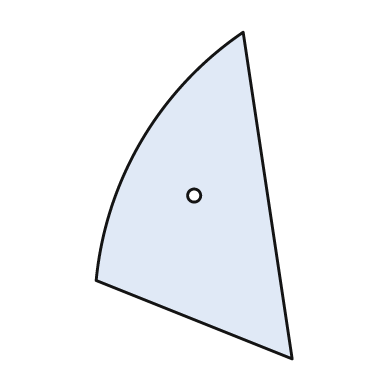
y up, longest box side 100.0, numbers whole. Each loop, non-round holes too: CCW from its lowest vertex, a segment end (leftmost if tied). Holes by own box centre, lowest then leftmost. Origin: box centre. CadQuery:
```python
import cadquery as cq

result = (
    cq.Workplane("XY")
    .moveTo(30.0, -50.0)
    .lineTo(15.0, 50.0)
    .threePointArc((-16.0, 17.0), (-30.0, -26.0))
    .close()
    .moveTo(0.0, 0.0)
    .circle(2.0)
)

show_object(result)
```